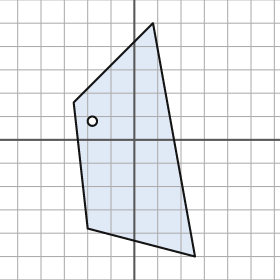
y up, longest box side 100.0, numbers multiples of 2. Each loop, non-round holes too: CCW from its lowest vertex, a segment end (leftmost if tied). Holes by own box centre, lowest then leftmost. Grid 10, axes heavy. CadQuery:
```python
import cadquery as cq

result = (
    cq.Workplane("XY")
    .moveTo(26.0, -50.0)
    .lineTo(8.0, 50.0)
    .lineTo(-26.0, 16.0)
    .lineTo(-20.0, -38.0)
    .close()
    .moveTo(-18.0, 8.0)
    .circle(2.0)
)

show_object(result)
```